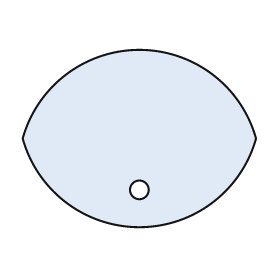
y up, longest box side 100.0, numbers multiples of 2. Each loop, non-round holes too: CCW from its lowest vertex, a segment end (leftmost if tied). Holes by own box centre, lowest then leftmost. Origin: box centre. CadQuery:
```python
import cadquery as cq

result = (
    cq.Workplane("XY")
    .moveTo(-50.0, 0.0)
    .threePointArc((0.0, -38.0), (50.0, 0.0))
    .threePointArc((0.0, 38.0), (-50.0, 0.0))
    .close()
    .moveTo(0.0, -22.0)
    .circle(4.0)
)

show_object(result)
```